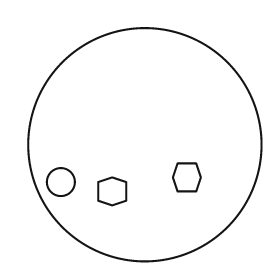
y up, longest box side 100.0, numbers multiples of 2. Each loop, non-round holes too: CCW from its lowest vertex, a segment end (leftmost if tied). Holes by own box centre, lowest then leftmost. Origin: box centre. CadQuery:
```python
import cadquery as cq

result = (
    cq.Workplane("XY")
    .moveTo(0.0, 0.0)
    .circle(50.0)
    .moveTo(-14.0, -26.0)
    .lineTo(-8.0, -24.0)
    .lineTo(-8.0, -16.0)
    .lineTo(-14.0, -14.0)
    .lineTo(-20.0, -16.0)
    .lineTo(-20.0, -24.0)
    .close()
    .moveTo(-36.0, -16.0)
    .circle(6.0)
    .moveTo(14.0, -20.0)
    .lineTo(22.0, -20.0)
    .lineTo(24.0, -14.0)
    .lineTo(22.0, -8.0)
    .lineTo(14.0, -8.0)
    .lineTo(12.0, -14.0)
    .close()
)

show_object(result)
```